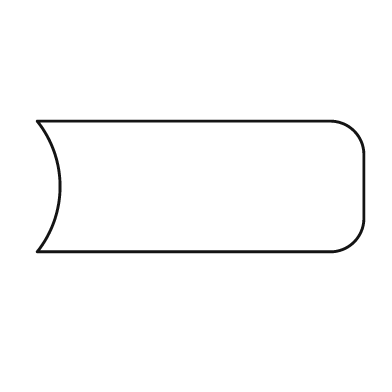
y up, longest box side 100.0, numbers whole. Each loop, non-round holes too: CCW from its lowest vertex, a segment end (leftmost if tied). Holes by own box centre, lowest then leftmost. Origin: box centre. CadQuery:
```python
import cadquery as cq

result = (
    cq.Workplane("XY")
    .moveTo(-50.0, -20.0)
    .lineTo(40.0, -20.0)
    .threePointArc((47.0, -17.0), (50.0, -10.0))
    .lineTo(50.0, 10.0)
    .threePointArc((47.0, 17.0), (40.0, 20.0))
    .lineTo(-50.0, 20.0)
    .threePointArc((-43.0, 0.0), (-50.0, -20.0))
    .close()
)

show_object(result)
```